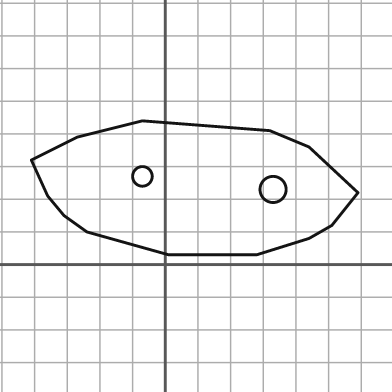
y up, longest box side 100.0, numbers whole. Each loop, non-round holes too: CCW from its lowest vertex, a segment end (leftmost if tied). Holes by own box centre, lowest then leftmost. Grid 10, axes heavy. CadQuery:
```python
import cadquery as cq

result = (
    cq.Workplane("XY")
    .moveTo(1.0, 3.0)
    .lineTo(28.0, 3.0)
    .lineTo(44.0, 8.0)
    .lineTo(51.0, 12.0)
    .lineTo(59.0, 22.0)
    .lineTo(44.0, 36.0)
    .lineTo(32.0, 41.0)
    .lineTo(-7.0, 44.0)
    .lineTo(-27.0, 39.0)
    .lineTo(-41.0, 32.0)
    .lineTo(-36.0, 21.0)
    .lineTo(-31.0, 15.0)
    .lineTo(-24.0, 10.0)
    .close()
    .moveTo(33.0, 23.0)
    .circle(4.0)
    .moveTo(-7.0, 27.0)
    .circle(3.0)
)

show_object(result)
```